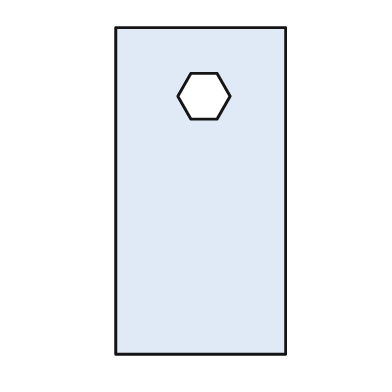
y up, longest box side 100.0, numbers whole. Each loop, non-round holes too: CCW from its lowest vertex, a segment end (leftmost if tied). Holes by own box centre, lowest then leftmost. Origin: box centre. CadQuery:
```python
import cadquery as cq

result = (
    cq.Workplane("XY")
    .moveTo(-26.0, -50.0)
    .lineTo(26.0, -50.0)
    .lineTo(26.0, 50.0)
    .lineTo(-26.0, 50.0)
    .close()
    .moveTo(-3.0, 22.0)
    .lineTo(5.0, 22.0)
    .lineTo(9.0, 29.0)
    .lineTo(5.0, 36.0)
    .lineTo(-3.0, 36.0)
    .lineTo(-7.0, 29.0)
    .close()
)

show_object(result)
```